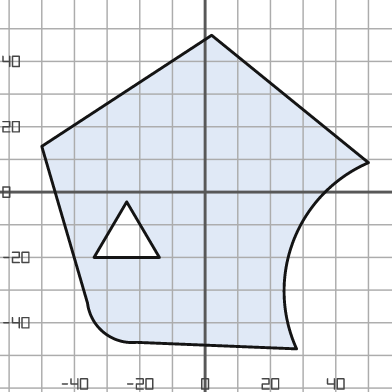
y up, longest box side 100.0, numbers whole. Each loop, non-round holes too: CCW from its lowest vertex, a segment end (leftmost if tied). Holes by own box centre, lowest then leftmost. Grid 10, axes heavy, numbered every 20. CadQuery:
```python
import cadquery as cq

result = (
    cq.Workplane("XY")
    .moveTo(28.0, -48.0)
    .threePointArc((27.0, -15.0), (50.0, 9.0))
    .lineTo(2.0, 48.0)
    .lineTo(-50.0, 14.0)
    .lineTo(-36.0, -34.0)
    .threePointArc((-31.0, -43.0), (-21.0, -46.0))
    .close()
    .moveTo(-34.0, -20.0)
    .lineTo(-14.0, -20.0)
    .lineTo(-24.0, -3.0)
    .close()
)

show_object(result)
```